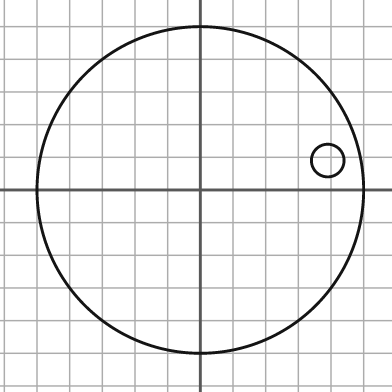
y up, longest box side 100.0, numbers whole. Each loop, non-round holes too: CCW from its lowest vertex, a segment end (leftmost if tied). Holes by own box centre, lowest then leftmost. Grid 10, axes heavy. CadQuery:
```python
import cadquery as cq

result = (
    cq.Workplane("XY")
    .moveTo(0.0, 0.0)
    .circle(50.0)
    .moveTo(39.0, 9.0)
    .circle(5.0)
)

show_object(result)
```